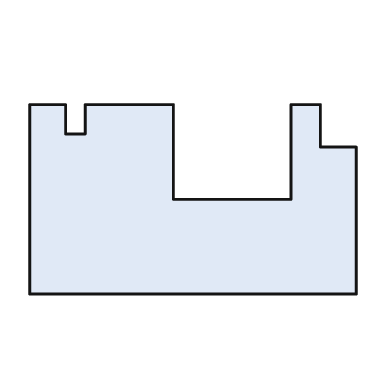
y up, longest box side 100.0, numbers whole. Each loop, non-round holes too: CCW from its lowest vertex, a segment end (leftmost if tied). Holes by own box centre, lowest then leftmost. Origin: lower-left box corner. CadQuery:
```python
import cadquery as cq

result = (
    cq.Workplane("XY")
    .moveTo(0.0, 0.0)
    .lineTo(100.0, 0.0)
    .lineTo(100.0, 45.0)
    .lineTo(89.0, 45.0)
    .lineTo(89.0, 58.0)
    .lineTo(80.0, 58.0)
    .lineTo(80.0, 29.0)
    .lineTo(44.0, 29.0)
    .lineTo(44.0, 58.0)
    .lineTo(17.0, 58.0)
    .lineTo(17.0, 49.0)
    .lineTo(11.0, 49.0)
    .lineTo(11.0, 58.0)
    .lineTo(0.0, 58.0)
    .close()
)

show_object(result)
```